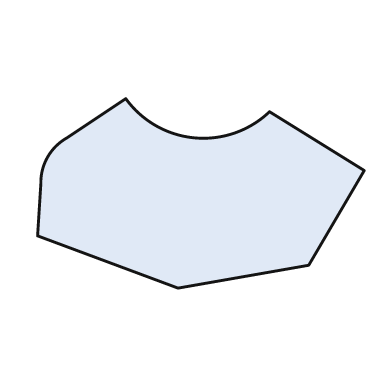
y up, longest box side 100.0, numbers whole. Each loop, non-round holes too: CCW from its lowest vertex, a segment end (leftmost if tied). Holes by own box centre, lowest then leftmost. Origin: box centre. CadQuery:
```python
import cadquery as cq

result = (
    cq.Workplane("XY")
    .moveTo(-7.0, -29.0)
    .lineTo(33.0, -22.0)
    .lineTo(50.0, 7.0)
    .lineTo(21.0, 25.0)
    .threePointArc((-2.0, 17.0), (-23.0, 29.0))
    .lineTo(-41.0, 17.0)
    .threePointArc((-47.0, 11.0), (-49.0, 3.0))
    .lineTo(-50.0, -13.0)
    .close()
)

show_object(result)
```